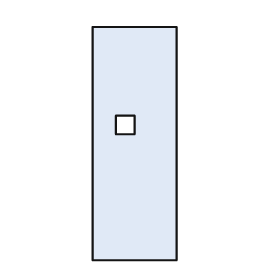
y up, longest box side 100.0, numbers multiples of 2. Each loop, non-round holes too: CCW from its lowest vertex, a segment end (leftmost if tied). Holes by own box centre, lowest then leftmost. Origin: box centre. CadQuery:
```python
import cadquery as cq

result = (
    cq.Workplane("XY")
    .moveTo(-18.0, -50.0)
    .lineTo(18.0, -50.0)
    .lineTo(18.0, 50.0)
    .lineTo(-18.0, 50.0)
    .close()
    .moveTo(-8.0, 4.0)
    .lineTo(0.0, 4.0)
    .lineTo(0.0, 12.0)
    .lineTo(-8.0, 12.0)
    .close()
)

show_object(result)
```